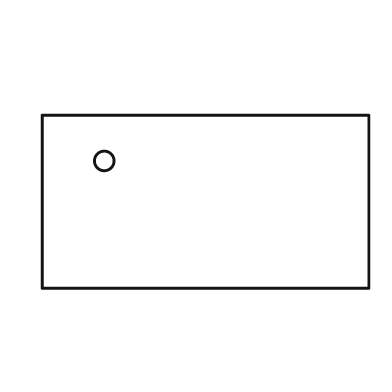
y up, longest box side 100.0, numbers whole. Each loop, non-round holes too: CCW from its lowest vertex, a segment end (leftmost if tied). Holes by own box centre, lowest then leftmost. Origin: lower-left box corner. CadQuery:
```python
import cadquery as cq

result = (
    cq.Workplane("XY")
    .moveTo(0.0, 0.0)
    .lineTo(100.0, 0.0)
    .lineTo(100.0, 53.0)
    .lineTo(0.0, 53.0)
    .close()
    .moveTo(19.0, 39.0)
    .circle(3.0)
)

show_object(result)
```